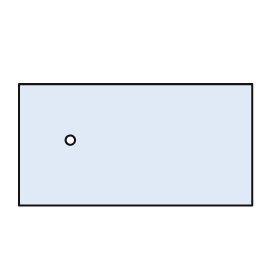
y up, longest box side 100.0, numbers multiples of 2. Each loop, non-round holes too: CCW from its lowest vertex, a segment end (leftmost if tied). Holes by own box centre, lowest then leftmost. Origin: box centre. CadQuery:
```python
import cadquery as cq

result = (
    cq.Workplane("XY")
    .moveTo(-50.0, -26.0)
    .lineTo(50.0, -26.0)
    .lineTo(50.0, 26.0)
    .lineTo(-50.0, 26.0)
    .close()
    .moveTo(-28.0, 2.0)
    .circle(2.0)
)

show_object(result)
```